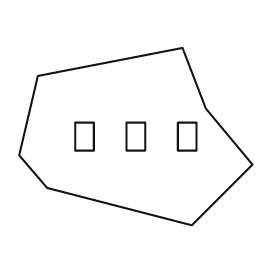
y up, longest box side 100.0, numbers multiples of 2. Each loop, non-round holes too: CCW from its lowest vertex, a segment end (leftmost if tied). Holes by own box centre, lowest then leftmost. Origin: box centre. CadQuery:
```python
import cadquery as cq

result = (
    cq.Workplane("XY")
    .moveTo(24.0, -38.0)
    .lineTo(50.0, -12.0)
    .lineTo(30.0, 12.0)
    .lineTo(20.0, 38.0)
    .lineTo(-42.0, 26.0)
    .lineTo(-50.0, -8.0)
    .lineTo(-38.0, -22.0)
    .close()
    .moveTo(-26.0, -6.0)
    .lineTo(-18.0, -6.0)
    .lineTo(-18.0, 6.0)
    .lineTo(-26.0, 6.0)
    .close()
    .moveTo(-4.0, -6.0)
    .lineTo(4.0, -6.0)
    .lineTo(4.0, 6.0)
    .lineTo(-4.0, 6.0)
    .close()
    .moveTo(18.0, -6.0)
    .lineTo(26.0, -6.0)
    .lineTo(26.0, 6.0)
    .lineTo(18.0, 6.0)
    .close()
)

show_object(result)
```